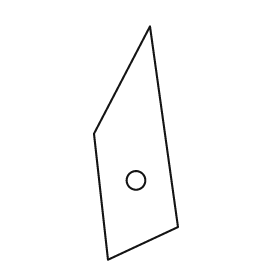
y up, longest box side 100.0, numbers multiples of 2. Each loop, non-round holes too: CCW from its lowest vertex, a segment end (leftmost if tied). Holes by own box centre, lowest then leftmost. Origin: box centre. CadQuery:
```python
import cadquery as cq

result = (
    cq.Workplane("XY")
    .moveTo(-12.0, -50.0)
    .lineTo(18.0, -36.0)
    .lineTo(6.0, 50.0)
    .lineTo(-18.0, 4.0)
    .close()
    .moveTo(0.0, -16.0)
    .circle(4.0)
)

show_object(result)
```